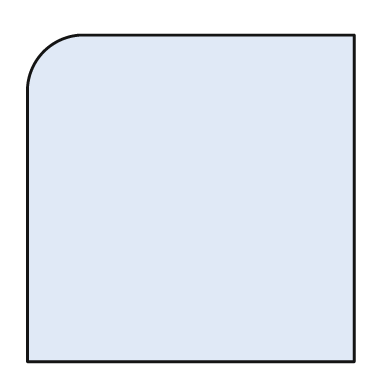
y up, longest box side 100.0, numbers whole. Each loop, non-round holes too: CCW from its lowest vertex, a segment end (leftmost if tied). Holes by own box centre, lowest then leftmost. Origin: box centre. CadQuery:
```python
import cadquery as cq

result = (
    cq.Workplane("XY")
    .moveTo(-50.0, -50.0)
    .lineTo(50.0, -50.0)
    .lineTo(50.0, 50.0)
    .lineTo(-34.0, 50.0)
    .threePointArc((-45.0, 45.0), (-50.0, 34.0))
    .close()
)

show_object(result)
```